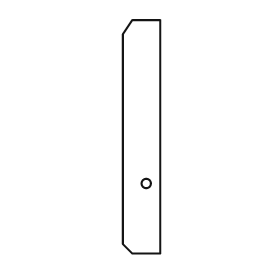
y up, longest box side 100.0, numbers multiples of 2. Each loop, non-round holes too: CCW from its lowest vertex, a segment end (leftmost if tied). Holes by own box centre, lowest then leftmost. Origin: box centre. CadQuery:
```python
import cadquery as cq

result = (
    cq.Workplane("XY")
    .moveTo(-4.0, -50.0)
    .lineTo(8.0, -50.0)
    .lineTo(8.0, 50.0)
    .lineTo(-4.0, 50.0)
    .lineTo(-8.0, 44.0)
    .lineTo(-8.0, -46.0)
    .close()
    .moveTo(2.0, -20.0)
    .circle(2.0)
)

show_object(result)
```